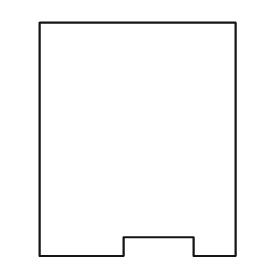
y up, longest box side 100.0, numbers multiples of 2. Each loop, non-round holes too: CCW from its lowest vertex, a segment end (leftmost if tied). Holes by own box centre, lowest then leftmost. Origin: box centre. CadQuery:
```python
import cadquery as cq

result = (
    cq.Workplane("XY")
    .moveTo(-42.0, -50.0)
    .lineTo(-6.0, -50.0)
    .lineTo(-6.0, -42.0)
    .lineTo(24.0, -42.0)
    .lineTo(24.0, -50.0)
    .lineTo(42.0, -50.0)
    .lineTo(42.0, 50.0)
    .lineTo(-42.0, 50.0)
    .close()
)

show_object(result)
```